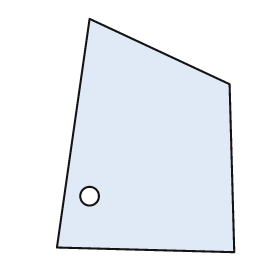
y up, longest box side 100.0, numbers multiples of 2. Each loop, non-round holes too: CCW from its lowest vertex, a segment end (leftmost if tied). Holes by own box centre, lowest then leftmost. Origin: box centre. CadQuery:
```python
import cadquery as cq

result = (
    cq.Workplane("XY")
    .moveTo(38.0, -50.0)
    .lineTo(36.0, 22.0)
    .lineTo(-24.0, 50.0)
    .lineTo(-38.0, -48.0)
    .close()
    .moveTo(-24.0, -26.0)
    .circle(4.0)
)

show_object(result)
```